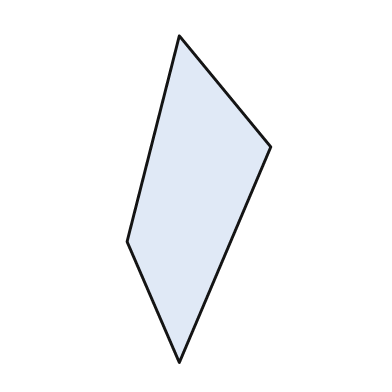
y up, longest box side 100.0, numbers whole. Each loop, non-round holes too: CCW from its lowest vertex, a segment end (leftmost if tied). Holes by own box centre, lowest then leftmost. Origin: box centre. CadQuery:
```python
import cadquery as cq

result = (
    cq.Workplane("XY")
    .moveTo(-6.0, -50.0)
    .lineTo(22.0, 16.0)
    .lineTo(-6.0, 50.0)
    .lineTo(-22.0, -13.0)
    .close()
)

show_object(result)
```